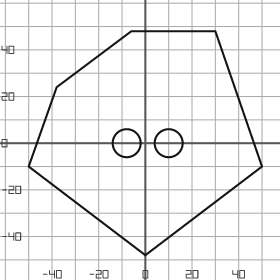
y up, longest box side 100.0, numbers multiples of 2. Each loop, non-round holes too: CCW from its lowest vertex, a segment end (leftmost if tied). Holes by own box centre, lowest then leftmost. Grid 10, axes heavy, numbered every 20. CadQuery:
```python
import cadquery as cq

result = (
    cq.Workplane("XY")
    .moveTo(0.0, -48.0)
    .lineTo(50.0, -10.0)
    .lineTo(30.0, 48.0)
    .lineTo(-6.0, 48.0)
    .lineTo(-38.0, 24.0)
    .lineTo(-50.0, -10.0)
    .close()
    .moveTo(-8.0, 0.0)
    .circle(6.0)
    .moveTo(10.0, 0.0)
    .circle(6.0)
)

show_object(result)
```